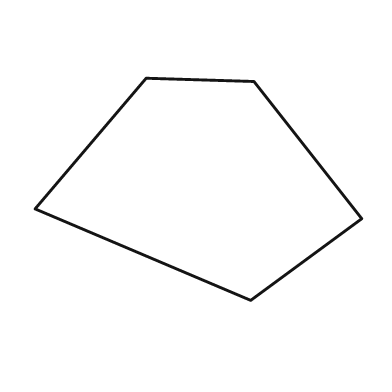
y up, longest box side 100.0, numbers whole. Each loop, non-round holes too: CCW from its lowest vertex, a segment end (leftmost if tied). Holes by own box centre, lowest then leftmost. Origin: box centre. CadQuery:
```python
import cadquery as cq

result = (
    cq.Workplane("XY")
    .moveTo(16.0, -34.0)
    .lineTo(50.0, -9.0)
    .lineTo(17.0, 33.0)
    .lineTo(-16.0, 34.0)
    .lineTo(-50.0, -6.0)
    .close()
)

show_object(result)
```